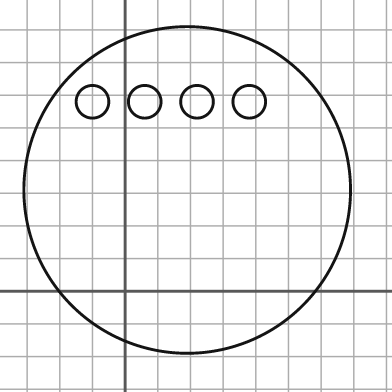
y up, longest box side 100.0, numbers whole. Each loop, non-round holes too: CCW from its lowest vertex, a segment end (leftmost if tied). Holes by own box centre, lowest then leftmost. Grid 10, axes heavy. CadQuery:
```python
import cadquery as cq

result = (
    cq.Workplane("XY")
    .moveTo(19.0, 31.0)
    .circle(50.0)
    .moveTo(-10.0, 58.0)
    .circle(5.0)
    .moveTo(6.0, 58.0)
    .circle(5.0)
    .moveTo(22.0, 58.0)
    .circle(5.0)
    .moveTo(38.0, 58.0)
    .circle(5.0)
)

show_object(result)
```